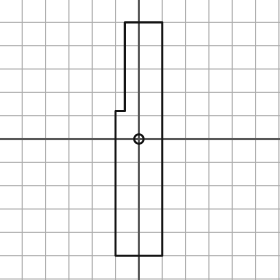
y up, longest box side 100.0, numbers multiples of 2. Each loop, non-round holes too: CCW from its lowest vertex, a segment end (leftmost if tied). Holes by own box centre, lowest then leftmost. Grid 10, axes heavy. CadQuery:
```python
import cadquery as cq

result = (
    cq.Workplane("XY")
    .moveTo(-10.0, -50.0)
    .lineTo(10.0, -50.0)
    .lineTo(10.0, 50.0)
    .lineTo(-6.0, 50.0)
    .lineTo(-6.0, 12.0)
    .lineTo(-10.0, 12.0)
    .close()
    .moveTo(0.0, 0.0)
    .circle(2.0)
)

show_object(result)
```